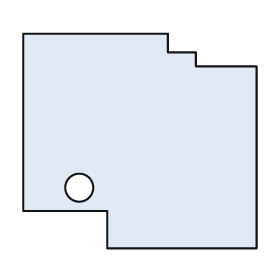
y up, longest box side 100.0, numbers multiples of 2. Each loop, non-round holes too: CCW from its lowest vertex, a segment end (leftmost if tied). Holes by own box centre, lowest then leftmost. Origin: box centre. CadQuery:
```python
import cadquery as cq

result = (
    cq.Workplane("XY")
    .moveTo(-14.0, -46.0)
    .lineTo(50.0, -46.0)
    .lineTo(50.0, 32.0)
    .lineTo(24.0, 32.0)
    .lineTo(24.0, 38.0)
    .lineTo(12.0, 38.0)
    .lineTo(12.0, 46.0)
    .lineTo(-50.0, 46.0)
    .lineTo(-50.0, -30.0)
    .lineTo(-14.0, -30.0)
    .close()
    .moveTo(-26.0, -20.0)
    .circle(6.0)
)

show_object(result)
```